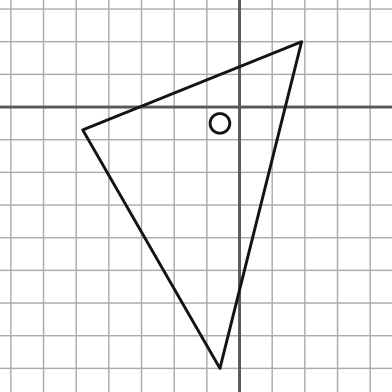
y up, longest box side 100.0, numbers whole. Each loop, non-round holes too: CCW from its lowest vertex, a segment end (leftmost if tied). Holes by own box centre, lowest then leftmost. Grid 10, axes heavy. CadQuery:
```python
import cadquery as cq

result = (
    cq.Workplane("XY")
    .moveTo(-6.0, -80.0)
    .lineTo(19.0, 20.0)
    .lineTo(-48.0, -7.0)
    .close()
    .moveTo(-6.0, -5.0)
    .circle(3.0)
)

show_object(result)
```